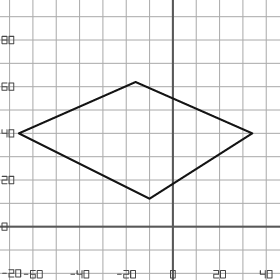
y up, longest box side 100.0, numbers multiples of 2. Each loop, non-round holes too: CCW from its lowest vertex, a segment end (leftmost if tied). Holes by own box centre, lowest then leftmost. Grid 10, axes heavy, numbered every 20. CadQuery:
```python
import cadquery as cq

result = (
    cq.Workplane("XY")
    .moveTo(-10.0, 12.0)
    .lineTo(34.0, 40.0)
    .lineTo(-16.0, 62.0)
    .lineTo(-66.0, 40.0)
    .close()
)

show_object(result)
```